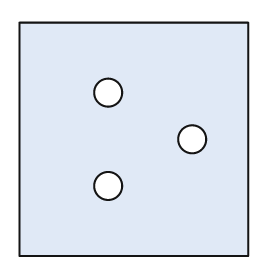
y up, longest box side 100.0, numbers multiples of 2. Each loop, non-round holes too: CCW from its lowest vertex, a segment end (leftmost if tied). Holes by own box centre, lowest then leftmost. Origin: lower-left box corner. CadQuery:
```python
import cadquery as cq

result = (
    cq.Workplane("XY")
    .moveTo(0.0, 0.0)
    .lineTo(98.0, 0.0)
    .lineTo(98.0, 100.0)
    .lineTo(0.0, 100.0)
    .close()
    .moveTo(38.0, 30.0)
    .circle(6.0)
    .moveTo(74.0, 50.0)
    .circle(6.0)
    .moveTo(38.0, 70.0)
    .circle(6.0)
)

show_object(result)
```